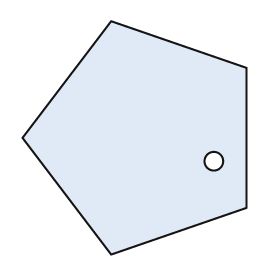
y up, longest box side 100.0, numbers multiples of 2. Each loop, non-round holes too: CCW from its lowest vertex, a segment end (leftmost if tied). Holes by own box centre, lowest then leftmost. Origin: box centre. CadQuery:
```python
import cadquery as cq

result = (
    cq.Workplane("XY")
    .moveTo(-10.0, -50.0)
    .lineTo(48.0, -30.0)
    .lineTo(48.0, 30.0)
    .lineTo(-10.0, 50.0)
    .lineTo(-48.0, 0.0)
    .close()
    .moveTo(34.0, -10.0)
    .circle(4.0)
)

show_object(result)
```